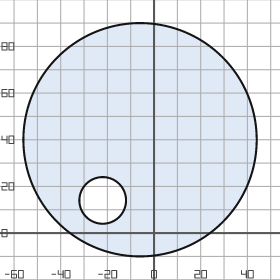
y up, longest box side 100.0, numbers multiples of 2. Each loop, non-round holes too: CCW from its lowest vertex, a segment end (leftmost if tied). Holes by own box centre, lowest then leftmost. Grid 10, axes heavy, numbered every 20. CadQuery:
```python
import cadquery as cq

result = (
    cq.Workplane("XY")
    .moveTo(-6.0, 40.0)
    .circle(50.0)
    .moveTo(-22.0, 14.0)
    .circle(10.0)
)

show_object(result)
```